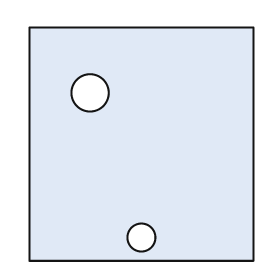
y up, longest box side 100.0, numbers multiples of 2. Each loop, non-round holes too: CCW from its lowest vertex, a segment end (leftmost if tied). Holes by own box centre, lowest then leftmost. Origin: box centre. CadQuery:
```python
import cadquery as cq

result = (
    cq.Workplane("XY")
    .moveTo(-48.0, -50.0)
    .lineTo(48.0, -50.0)
    .lineTo(48.0, 50.0)
    .lineTo(-48.0, 50.0)
    .close()
    .moveTo(0.0, -40.0)
    .circle(6.0)
    .moveTo(-22.0, 22.0)
    .circle(8.0)
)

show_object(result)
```